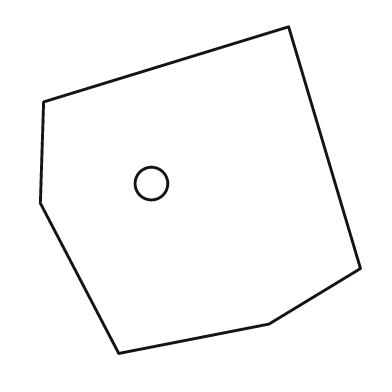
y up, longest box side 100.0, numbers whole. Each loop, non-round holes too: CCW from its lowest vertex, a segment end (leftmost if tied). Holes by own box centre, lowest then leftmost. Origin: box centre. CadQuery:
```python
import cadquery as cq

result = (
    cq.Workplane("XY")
    .moveTo(-25.0, -50.0)
    .lineTo(21.0, -41.0)
    .lineTo(49.0, -24.0)
    .lineTo(27.0, 50.0)
    .lineTo(-48.0, 27.0)
    .lineTo(-49.0, -4.0)
    .close()
    .moveTo(-15.0, 2.0)
    .circle(5.0)
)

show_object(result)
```